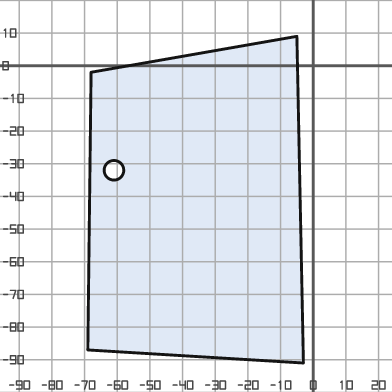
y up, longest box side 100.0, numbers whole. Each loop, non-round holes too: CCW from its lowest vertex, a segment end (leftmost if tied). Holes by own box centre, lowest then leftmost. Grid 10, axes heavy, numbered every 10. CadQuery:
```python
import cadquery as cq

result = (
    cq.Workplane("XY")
    .moveTo(-3.0, -91.0)
    .lineTo(-5.0, 9.0)
    .lineTo(-68.0, -2.0)
    .lineTo(-69.0, -87.0)
    .close()
    .moveTo(-61.0, -32.0)
    .circle(3.0)
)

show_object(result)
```